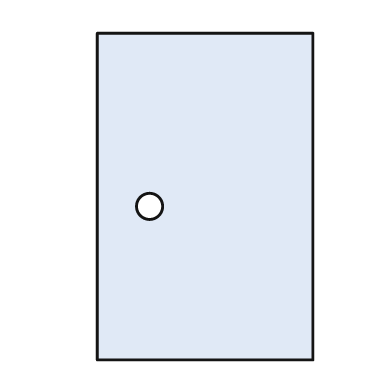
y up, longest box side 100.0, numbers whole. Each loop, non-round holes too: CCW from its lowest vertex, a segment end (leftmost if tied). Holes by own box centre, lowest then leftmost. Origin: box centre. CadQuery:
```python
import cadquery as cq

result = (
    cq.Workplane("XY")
    .moveTo(-33.0, -50.0)
    .lineTo(33.0, -50.0)
    .lineTo(33.0, 50.0)
    .lineTo(-33.0, 50.0)
    .close()
    .moveTo(-17.0, -3.0)
    .circle(4.0)
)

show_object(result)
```